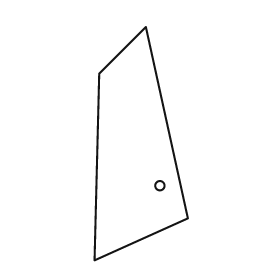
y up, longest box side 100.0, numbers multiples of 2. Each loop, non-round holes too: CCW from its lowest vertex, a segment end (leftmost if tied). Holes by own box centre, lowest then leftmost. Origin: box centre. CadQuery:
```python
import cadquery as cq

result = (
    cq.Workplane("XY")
    .moveTo(-20.0, -50.0)
    .lineTo(20.0, -32.0)
    .lineTo(2.0, 50.0)
    .lineTo(-18.0, 30.0)
    .close()
    .moveTo(8.0, -18.0)
    .circle(2.0)
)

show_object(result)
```